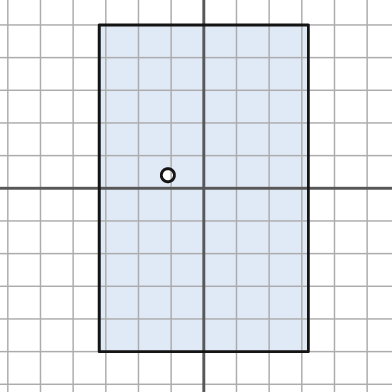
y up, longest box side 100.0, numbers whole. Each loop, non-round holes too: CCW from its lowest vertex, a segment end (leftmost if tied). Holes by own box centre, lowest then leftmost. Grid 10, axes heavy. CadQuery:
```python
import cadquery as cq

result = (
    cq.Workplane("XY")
    .moveTo(-32.0, -50.0)
    .lineTo(32.0, -50.0)
    .lineTo(32.0, 50.0)
    .lineTo(-32.0, 50.0)
    .close()
    .moveTo(-11.0, 4.0)
    .circle(2.0)
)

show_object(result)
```